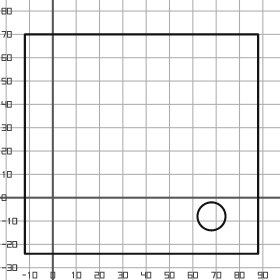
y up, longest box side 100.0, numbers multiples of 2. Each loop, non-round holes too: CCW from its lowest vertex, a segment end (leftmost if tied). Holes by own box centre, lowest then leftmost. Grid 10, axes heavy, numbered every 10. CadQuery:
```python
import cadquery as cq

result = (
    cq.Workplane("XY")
    .moveTo(-12.0, -24.0)
    .lineTo(88.0, -24.0)
    .lineTo(88.0, 70.0)
    .lineTo(-12.0, 70.0)
    .close()
    .moveTo(68.0, -8.0)
    .circle(6.0)
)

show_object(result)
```